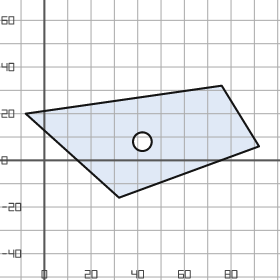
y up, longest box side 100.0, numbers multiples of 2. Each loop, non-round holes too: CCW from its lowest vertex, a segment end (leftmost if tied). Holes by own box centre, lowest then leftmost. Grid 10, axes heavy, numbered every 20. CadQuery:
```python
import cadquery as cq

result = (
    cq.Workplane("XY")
    .moveTo(32.0, -16.0)
    .lineTo(92.0, 6.0)
    .lineTo(76.0, 32.0)
    .lineTo(-8.0, 20.0)
    .close()
    .moveTo(42.0, 8.0)
    .circle(4.0)
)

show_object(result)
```